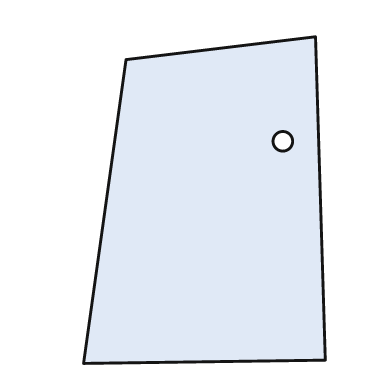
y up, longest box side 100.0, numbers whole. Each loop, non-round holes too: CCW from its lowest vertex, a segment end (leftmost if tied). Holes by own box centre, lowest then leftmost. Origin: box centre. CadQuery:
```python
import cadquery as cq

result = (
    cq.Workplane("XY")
    .moveTo(-37.0, -50.0)
    .lineTo(37.0, -49.0)
    .lineTo(34.0, 50.0)
    .lineTo(-24.0, 43.0)
    .close()
    .moveTo(24.0, 18.0)
    .circle(3.0)
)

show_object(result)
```